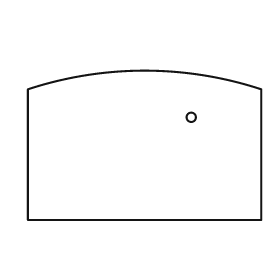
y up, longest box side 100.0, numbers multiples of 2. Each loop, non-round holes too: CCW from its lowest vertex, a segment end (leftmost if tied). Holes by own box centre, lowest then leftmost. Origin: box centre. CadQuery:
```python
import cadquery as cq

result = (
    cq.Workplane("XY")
    .moveTo(-50.0, -32.0)
    .lineTo(50.0, -32.0)
    .lineTo(50.0, 24.0)
    .threePointArc((0.0, 32.0), (-50.0, 24.0))
    .close()
    .moveTo(20.0, 12.0)
    .circle(2.0)
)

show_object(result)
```